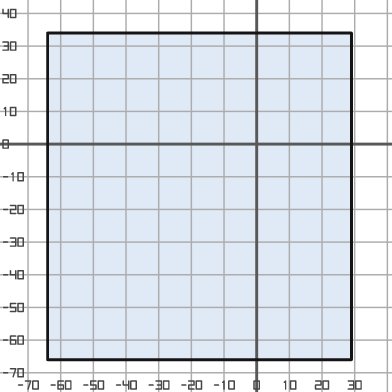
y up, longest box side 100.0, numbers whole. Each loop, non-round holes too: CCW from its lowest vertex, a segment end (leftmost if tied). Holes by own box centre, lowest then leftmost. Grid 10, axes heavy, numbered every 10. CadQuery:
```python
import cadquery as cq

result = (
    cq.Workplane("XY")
    .moveTo(-64.0, -66.0)
    .lineTo(29.0, -66.0)
    .lineTo(29.0, 34.0)
    .lineTo(-64.0, 34.0)
    .close()
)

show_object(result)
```